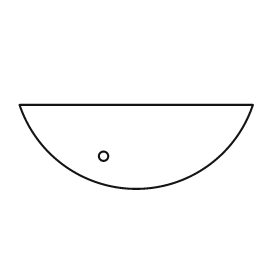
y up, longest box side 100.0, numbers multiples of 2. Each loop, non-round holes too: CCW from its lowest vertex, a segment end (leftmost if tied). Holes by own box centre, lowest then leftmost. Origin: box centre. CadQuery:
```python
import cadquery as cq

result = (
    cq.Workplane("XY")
    .moveTo(-50.0, 18.0)
    .threePointArc((0.0, -18.0), (50.0, 18.0))
    .close()
    .moveTo(-14.0, -4.0)
    .circle(2.0)
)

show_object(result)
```